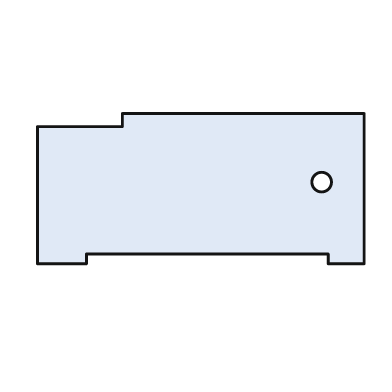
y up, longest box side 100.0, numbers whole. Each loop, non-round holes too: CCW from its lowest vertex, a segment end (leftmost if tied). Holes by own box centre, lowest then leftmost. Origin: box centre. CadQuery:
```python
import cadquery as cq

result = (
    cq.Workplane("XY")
    .moveTo(-50.0, -23.0)
    .lineTo(-35.0, -23.0)
    .lineTo(-35.0, -20.0)
    .lineTo(39.0, -20.0)
    .lineTo(39.0, -23.0)
    .lineTo(50.0, -23.0)
    .lineTo(50.0, 23.0)
    .lineTo(-24.0, 23.0)
    .lineTo(-24.0, 19.0)
    .lineTo(-50.0, 19.0)
    .close()
    .moveTo(37.0, 2.0)
    .circle(3.0)
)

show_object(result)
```